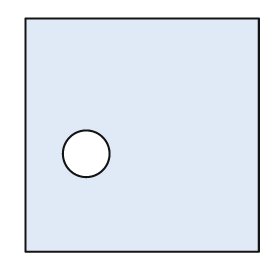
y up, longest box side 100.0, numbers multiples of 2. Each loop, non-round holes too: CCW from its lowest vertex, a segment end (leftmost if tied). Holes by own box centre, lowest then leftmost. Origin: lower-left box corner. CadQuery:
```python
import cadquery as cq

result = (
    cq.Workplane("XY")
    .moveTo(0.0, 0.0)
    .lineTo(100.0, 0.0)
    .lineTo(100.0, 100.0)
    .lineTo(0.0, 100.0)
    .close()
    .moveTo(26.0, 42.0)
    .circle(10.0)
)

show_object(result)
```